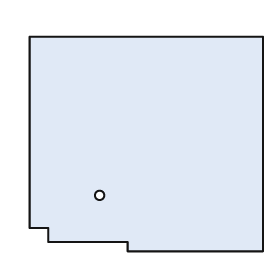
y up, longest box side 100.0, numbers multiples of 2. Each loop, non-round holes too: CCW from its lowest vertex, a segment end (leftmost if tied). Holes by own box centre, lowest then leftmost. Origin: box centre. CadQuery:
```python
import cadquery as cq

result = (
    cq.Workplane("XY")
    .moveTo(-8.0, -46.0)
    .lineTo(50.0, -46.0)
    .lineTo(50.0, 46.0)
    .lineTo(-50.0, 46.0)
    .lineTo(-50.0, -36.0)
    .lineTo(-42.0, -36.0)
    .lineTo(-42.0, -42.0)
    .lineTo(-8.0, -42.0)
    .close()
    .moveTo(-20.0, -22.0)
    .circle(2.0)
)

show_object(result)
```